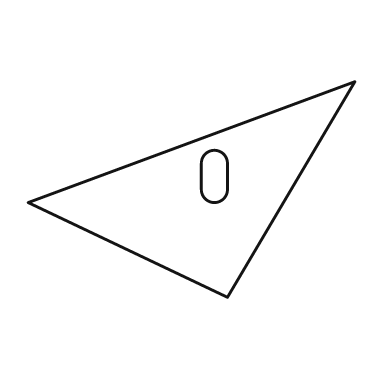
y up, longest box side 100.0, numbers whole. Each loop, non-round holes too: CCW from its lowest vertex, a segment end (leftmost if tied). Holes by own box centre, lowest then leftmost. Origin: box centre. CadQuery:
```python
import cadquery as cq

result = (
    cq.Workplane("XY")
    .moveTo(11.0, -33.0)
    .lineTo(50.0, 33.0)
    .lineTo(-50.0, -4.0)
    .close()
    .moveTo(3.0, 0.0)
    .threePointArc((7.0, -4.0), (11.0, 0.0))
    .lineTo(11.0, 8.0)
    .threePointArc((7.0, 12.0), (3.0, 8.0))
    .close()
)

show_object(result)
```